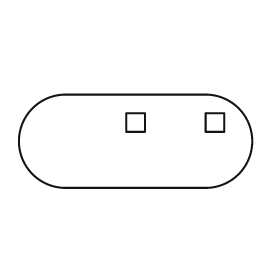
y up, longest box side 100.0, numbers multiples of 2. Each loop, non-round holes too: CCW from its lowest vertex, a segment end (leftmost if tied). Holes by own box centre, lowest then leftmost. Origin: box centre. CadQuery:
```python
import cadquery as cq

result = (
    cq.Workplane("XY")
    .moveTo(-30.0, -20.0)
    .lineTo(30.0, -20.0)
    .threePointArc((50.0, 0.0), (30.0, 20.0))
    .lineTo(-30.0, 20.0)
    .threePointArc((-50.0, 0.0), (-30.0, -20.0))
    .close()
    .moveTo(-4.0, 4.0)
    .lineTo(4.0, 4.0)
    .lineTo(4.0, 12.0)
    .lineTo(-4.0, 12.0)
    .close()
    .moveTo(30.0, 4.0)
    .lineTo(38.0, 4.0)
    .lineTo(38.0, 12.0)
    .lineTo(30.0, 12.0)
    .close()
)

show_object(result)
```